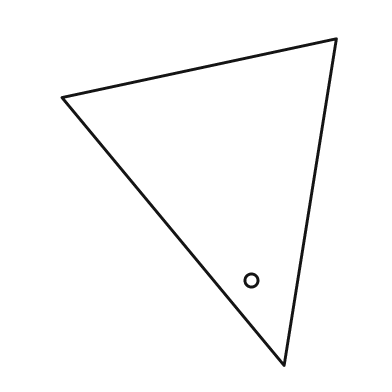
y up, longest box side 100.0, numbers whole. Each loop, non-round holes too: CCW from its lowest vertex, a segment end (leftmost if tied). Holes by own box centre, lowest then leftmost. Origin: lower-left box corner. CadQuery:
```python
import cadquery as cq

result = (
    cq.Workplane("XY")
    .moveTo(68.0, 0.0)
    .lineTo(84.0, 100.0)
    .lineTo(0.0, 82.0)
    .close()
    .moveTo(58.0, 26.0)
    .circle(2.0)
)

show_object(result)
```